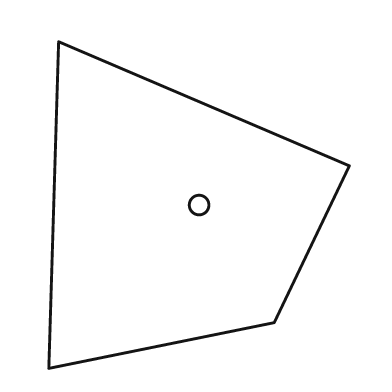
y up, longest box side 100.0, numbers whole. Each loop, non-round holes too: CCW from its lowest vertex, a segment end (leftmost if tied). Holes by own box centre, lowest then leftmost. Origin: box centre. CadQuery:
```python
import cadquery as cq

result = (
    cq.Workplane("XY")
    .moveTo(-46.0, -50.0)
    .lineTo(23.0, -36.0)
    .lineTo(46.0, 12.0)
    .lineTo(-43.0, 50.0)
    .close()
    .moveTo(0.0, 0.0)
    .circle(3.0)
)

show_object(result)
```